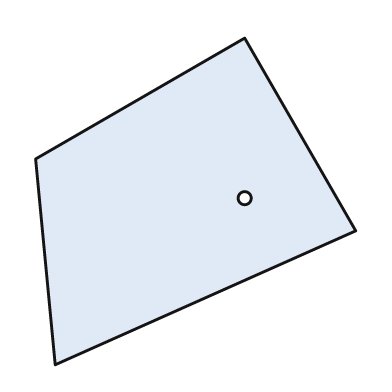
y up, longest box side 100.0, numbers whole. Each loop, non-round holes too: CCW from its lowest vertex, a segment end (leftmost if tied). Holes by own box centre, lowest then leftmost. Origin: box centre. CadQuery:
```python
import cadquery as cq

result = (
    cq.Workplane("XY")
    .moveTo(-43.0, -50.0)
    .lineTo(49.0, -9.0)
    .lineTo(15.0, 50.0)
    .lineTo(-49.0, 13.0)
    .close()
    .moveTo(15.0, 1.0)
    .circle(2.0)
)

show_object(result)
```